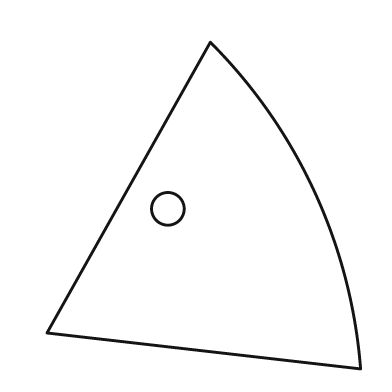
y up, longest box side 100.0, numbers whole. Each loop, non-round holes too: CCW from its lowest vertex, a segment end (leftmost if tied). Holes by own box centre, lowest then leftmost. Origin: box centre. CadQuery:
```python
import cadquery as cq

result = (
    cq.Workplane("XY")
    .moveTo(48.0, -50.0)
    .threePointArc((34.0, 4.0), (2.0, 50.0))
    .lineTo(-48.0, -39.0)
    .close()
    .moveTo(-11.0, -1.0)
    .circle(5.0)
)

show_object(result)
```